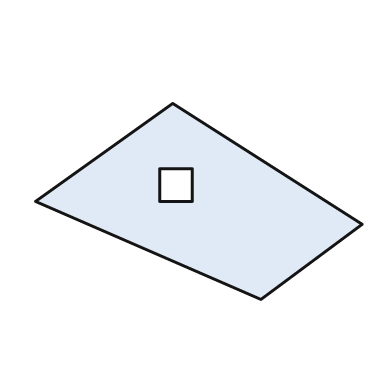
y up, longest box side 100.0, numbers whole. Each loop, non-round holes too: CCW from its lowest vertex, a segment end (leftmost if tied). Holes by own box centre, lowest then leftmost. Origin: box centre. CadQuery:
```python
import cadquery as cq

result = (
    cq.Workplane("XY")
    .moveTo(19.0, -30.0)
    .lineTo(50.0, -7.0)
    .lineTo(-8.0, 30.0)
    .lineTo(-50.0, 0.0)
    .close()
    .moveTo(-12.0, 0.0)
    .lineTo(-2.0, 0.0)
    .lineTo(-2.0, 10.0)
    .lineTo(-12.0, 10.0)
    .close()
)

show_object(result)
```